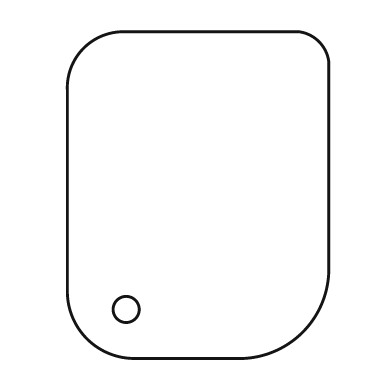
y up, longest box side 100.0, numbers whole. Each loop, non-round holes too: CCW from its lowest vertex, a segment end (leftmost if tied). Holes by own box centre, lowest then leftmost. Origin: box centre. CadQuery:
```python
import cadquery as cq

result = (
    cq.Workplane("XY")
    .moveTo(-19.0, -50.0)
    .lineTo(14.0, -50.0)
    .threePointArc((32.0, -42.0), (40.0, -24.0))
    .lineTo(40.0, 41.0)
    .threePointArc((37.0, 47.0), (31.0, 50.0))
    .lineTo(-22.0, 50.0)
    .threePointArc((-35.0, 45.0), (-40.0, 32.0))
    .lineTo(-40.0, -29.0)
    .threePointArc((-34.0, -44.0), (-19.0, -50.0))
    .close()
    .moveTo(-22.0, -35.0)
    .circle(4.0)
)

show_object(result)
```